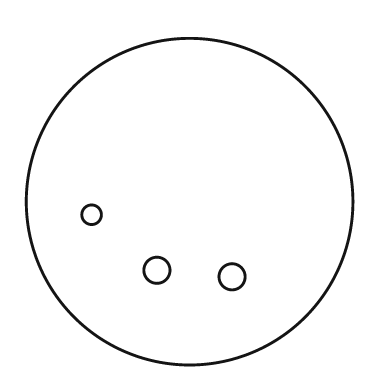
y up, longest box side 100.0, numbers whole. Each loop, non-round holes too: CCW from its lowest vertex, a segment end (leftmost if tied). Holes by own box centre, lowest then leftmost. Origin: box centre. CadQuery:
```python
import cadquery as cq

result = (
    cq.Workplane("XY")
    .moveTo(0.0, 0.0)
    .circle(50.0)
    .moveTo(13.0, -23.0)
    .circle(4.0)
    .moveTo(-10.0, -21.0)
    .circle(4.0)
    .moveTo(-30.0, -4.0)
    .circle(3.0)
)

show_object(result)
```